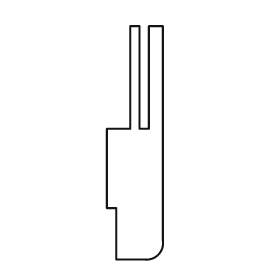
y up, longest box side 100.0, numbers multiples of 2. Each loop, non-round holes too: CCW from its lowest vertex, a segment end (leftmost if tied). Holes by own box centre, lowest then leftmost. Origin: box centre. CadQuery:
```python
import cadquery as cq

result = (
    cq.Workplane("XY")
    .moveTo(-8.0, -50.0)
    .lineTo(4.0, -50.0)
    .threePointArc((10.0, -48.0), (12.0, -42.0))
    .lineTo(12.0, 50.0)
    .lineTo(6.0, 50.0)
    .lineTo(6.0, 6.0)
    .lineTo(2.0, 6.0)
    .lineTo(2.0, 50.0)
    .lineTo(-2.0, 50.0)
    .lineTo(-2.0, 6.0)
    .lineTo(-12.0, 6.0)
    .lineTo(-12.0, -28.0)
    .lineTo(-8.0, -28.0)
    .close()
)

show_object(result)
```